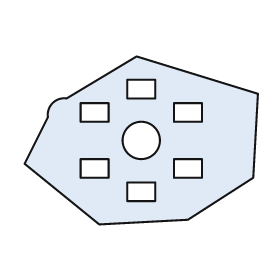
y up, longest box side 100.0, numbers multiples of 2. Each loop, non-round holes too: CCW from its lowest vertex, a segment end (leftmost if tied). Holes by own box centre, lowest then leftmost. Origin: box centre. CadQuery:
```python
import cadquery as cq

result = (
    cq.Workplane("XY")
    .moveTo(-18.0, -36.0)
    .lineTo(20.0, -34.0)
    .lineTo(48.0, -16.0)
    .lineTo(50.0, 20.0)
    .lineTo(-2.0, 36.0)
    .lineTo(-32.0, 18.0)
    .threePointArc((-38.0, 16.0), (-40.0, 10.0))
    .lineTo(-50.0, -10.0)
    .close()
    .moveTo(-6.0, -26.0)
    .lineTo(6.0, -26.0)
    .lineTo(6.0, -18.0)
    .lineTo(-6.0, -18.0)
    .close()
    .moveTo(-26.0, -16.0)
    .lineTo(-14.0, -16.0)
    .lineTo(-14.0, -8.0)
    .lineTo(-26.0, -8.0)
    .close()
    .moveTo(14.0, -16.0)
    .lineTo(26.0, -16.0)
    .lineTo(26.0, -8.0)
    .lineTo(14.0, -8.0)
    .close()
    .moveTo(0.0, 0.0)
    .circle(8.0)
    .moveTo(-26.0, 8.0)
    .lineTo(-14.0, 8.0)
    .lineTo(-14.0, 16.0)
    .lineTo(-26.0, 16.0)
    .close()
    .moveTo(14.0, 8.0)
    .lineTo(26.0, 8.0)
    .lineTo(26.0, 16.0)
    .lineTo(14.0, 16.0)
    .close()
    .moveTo(-6.0, 18.0)
    .lineTo(6.0, 18.0)
    .lineTo(6.0, 26.0)
    .lineTo(-6.0, 26.0)
    .close()
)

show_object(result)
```